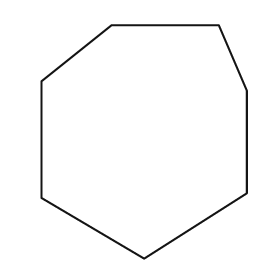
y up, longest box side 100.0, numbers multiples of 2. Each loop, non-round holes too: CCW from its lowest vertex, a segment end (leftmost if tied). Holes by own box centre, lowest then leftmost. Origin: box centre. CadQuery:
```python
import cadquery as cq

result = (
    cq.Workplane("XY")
    .moveTo(0.0, -50.0)
    .lineTo(44.0, -22.0)
    .lineTo(44.0, 22.0)
    .lineTo(32.0, 50.0)
    .lineTo(-14.0, 50.0)
    .lineTo(-44.0, 26.0)
    .lineTo(-44.0, -24.0)
    .close()
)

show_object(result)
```